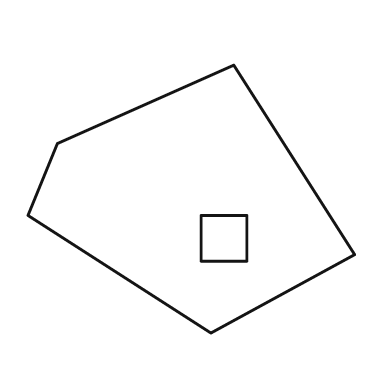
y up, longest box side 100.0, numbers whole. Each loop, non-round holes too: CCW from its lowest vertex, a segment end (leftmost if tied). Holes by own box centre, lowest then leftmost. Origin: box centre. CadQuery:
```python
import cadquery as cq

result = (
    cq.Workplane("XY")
    .moveTo(6.0, -41.0)
    .lineTo(50.0, -17.0)
    .lineTo(13.0, 41.0)
    .lineTo(-41.0, 17.0)
    .lineTo(-50.0, -5.0)
    .close()
    .moveTo(3.0, -19.0)
    .lineTo(17.0, -19.0)
    .lineTo(17.0, -5.0)
    .lineTo(3.0, -5.0)
    .close()
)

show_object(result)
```